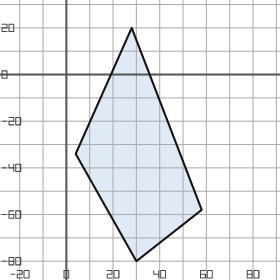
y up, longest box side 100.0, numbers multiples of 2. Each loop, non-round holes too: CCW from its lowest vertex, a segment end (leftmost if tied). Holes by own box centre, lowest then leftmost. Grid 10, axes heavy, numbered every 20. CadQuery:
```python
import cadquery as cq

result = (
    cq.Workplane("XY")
    .moveTo(30.0, -80.0)
    .lineTo(58.0, -58.0)
    .lineTo(28.0, 20.0)
    .lineTo(4.0, -34.0)
    .close()
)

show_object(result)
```